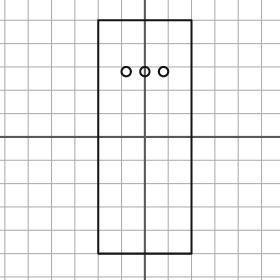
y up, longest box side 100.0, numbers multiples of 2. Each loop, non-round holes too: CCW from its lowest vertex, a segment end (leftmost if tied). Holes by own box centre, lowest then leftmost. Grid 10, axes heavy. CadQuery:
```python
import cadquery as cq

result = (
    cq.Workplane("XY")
    .moveTo(-20.0, -50.0)
    .lineTo(20.0, -50.0)
    .lineTo(20.0, 50.0)
    .lineTo(-20.0, 50.0)
    .close()
    .moveTo(-8.0, 28.0)
    .circle(2.0)
    .moveTo(0.0, 28.0)
    .circle(2.0)
    .moveTo(8.0, 28.0)
    .circle(2.0)
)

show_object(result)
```